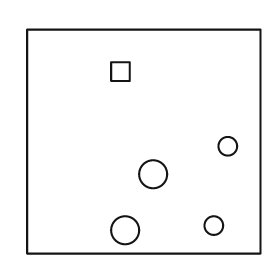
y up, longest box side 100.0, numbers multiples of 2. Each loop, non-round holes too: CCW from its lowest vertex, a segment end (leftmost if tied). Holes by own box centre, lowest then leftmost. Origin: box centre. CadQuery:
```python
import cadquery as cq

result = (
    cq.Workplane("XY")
    .moveTo(-50.0, -48.0)
    .lineTo(50.0, -48.0)
    .lineTo(50.0, 48.0)
    .lineTo(-50.0, 48.0)
    .close()
    .moveTo(-8.0, -38.0)
    .circle(6.0)
    .moveTo(30.0, -36.0)
    .circle(4.0)
    .moveTo(4.0, -14.0)
    .circle(6.0)
    .moveTo(36.0, -2.0)
    .circle(4.0)
    .moveTo(-14.0, 26.0)
    .lineTo(-6.0, 26.0)
    .lineTo(-6.0, 34.0)
    .lineTo(-14.0, 34.0)
    .close()
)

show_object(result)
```